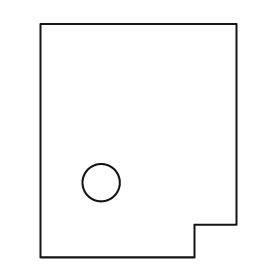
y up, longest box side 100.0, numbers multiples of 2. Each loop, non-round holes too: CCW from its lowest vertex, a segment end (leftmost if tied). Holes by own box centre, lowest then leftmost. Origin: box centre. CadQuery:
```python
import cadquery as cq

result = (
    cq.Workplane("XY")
    .moveTo(-42.0, -50.0)
    .lineTo(24.0, -50.0)
    .lineTo(24.0, -36.0)
    .lineTo(42.0, -36.0)
    .lineTo(42.0, 50.0)
    .lineTo(-42.0, 50.0)
    .close()
    .moveTo(-16.0, -18.0)
    .circle(8.0)
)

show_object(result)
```